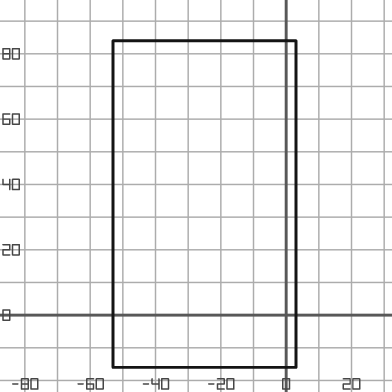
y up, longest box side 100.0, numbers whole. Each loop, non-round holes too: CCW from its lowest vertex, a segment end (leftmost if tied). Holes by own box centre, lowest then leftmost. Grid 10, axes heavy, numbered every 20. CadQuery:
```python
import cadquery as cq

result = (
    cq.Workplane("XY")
    .moveTo(-53.0, -16.0)
    .lineTo(3.0, -16.0)
    .lineTo(3.0, 84.0)
    .lineTo(-53.0, 84.0)
    .close()
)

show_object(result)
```